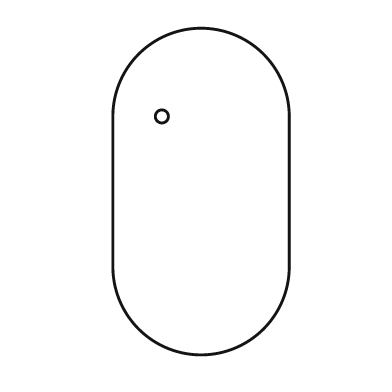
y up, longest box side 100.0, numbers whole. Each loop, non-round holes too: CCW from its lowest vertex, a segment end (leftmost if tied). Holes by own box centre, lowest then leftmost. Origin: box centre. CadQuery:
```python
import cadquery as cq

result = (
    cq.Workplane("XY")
    .moveTo(-27.0, -23.0)
    .threePointArc((0.0, -50.0), (27.0, -23.0))
    .lineTo(27.0, 23.0)
    .threePointArc((0.0, 50.0), (-27.0, 23.0))
    .close()
    .moveTo(-12.0, 23.0)
    .circle(2.0)
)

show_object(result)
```